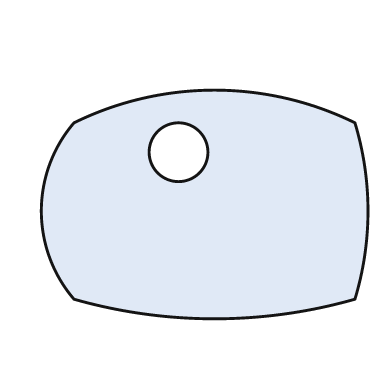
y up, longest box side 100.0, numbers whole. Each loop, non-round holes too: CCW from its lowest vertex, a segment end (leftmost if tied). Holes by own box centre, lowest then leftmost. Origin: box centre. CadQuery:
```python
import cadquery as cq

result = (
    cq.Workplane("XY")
    .moveTo(-40.0, -29.0)
    .threePointArc((3.0, -35.0), (46.0, -29.0))
    .threePointArc((50.0, -2.0), (46.0, 25.0))
    .threePointArc((3.0, 35.0), (-40.0, 25.0))
    .threePointArc((-50.0, -2.0), (-40.0, -29.0))
    .close()
    .moveTo(-8.0, 16.0)
    .circle(9.0)
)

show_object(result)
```